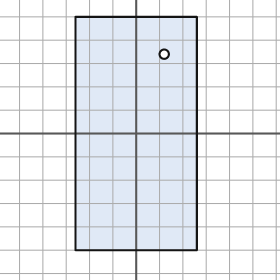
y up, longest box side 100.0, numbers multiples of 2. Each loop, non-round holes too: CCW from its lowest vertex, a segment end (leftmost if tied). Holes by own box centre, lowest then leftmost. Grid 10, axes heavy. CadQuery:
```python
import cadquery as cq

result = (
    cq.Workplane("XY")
    .moveTo(-26.0, -50.0)
    .lineTo(26.0, -50.0)
    .lineTo(26.0, 50.0)
    .lineTo(-26.0, 50.0)
    .close()
    .moveTo(12.0, 34.0)
    .circle(2.0)
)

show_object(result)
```